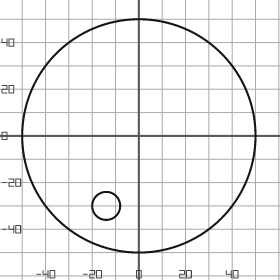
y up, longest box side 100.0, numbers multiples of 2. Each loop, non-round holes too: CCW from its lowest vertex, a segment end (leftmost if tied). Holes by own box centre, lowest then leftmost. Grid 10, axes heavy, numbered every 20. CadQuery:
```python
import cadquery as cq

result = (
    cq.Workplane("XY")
    .moveTo(0.0, 0.0)
    .circle(50.0)
    .moveTo(-14.0, -30.0)
    .circle(6.0)
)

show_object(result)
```